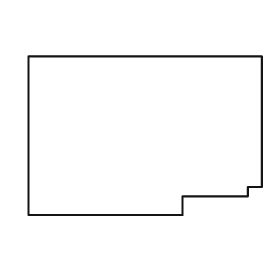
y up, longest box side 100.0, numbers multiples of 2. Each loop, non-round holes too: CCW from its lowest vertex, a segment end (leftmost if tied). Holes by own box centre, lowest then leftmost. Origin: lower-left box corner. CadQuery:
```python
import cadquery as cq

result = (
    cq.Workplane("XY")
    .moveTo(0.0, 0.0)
    .lineTo(66.0, 0.0)
    .lineTo(66.0, 8.0)
    .lineTo(94.0, 8.0)
    .lineTo(94.0, 12.0)
    .lineTo(100.0, 12.0)
    .lineTo(100.0, 68.0)
    .lineTo(0.0, 68.0)
    .close()
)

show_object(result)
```